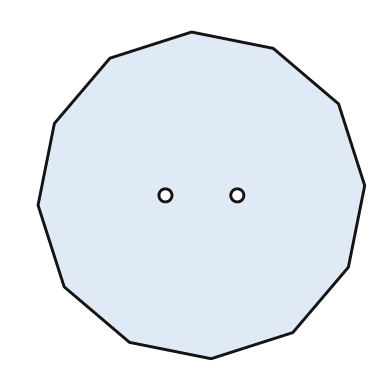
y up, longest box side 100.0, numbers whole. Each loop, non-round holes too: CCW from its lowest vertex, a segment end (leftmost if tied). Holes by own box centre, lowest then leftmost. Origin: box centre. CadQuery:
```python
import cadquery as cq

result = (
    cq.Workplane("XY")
    .moveTo(3.0, -50.0)
    .lineTo(28.0, -42.0)
    .lineTo(45.0, -22.0)
    .lineTo(50.0, 3.0)
    .lineTo(42.0, 28.0)
    .lineTo(22.0, 45.0)
    .lineTo(-3.0, 50.0)
    .lineTo(-28.0, 42.0)
    .lineTo(-45.0, 22.0)
    .lineTo(-50.0, -3.0)
    .lineTo(-42.0, -28.0)
    .lineTo(-22.0, -45.0)
    .close()
    .moveTo(-11.0, 0.0)
    .circle(2.0)
    .moveTo(11.0, 0.0)
    .circle(2.0)
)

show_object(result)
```